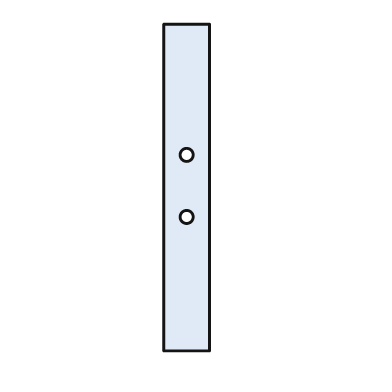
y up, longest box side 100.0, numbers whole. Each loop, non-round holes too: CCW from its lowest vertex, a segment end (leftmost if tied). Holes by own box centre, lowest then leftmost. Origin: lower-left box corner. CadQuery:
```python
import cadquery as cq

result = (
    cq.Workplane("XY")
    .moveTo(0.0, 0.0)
    .lineTo(14.0, 0.0)
    .lineTo(14.0, 100.0)
    .lineTo(0.0, 100.0)
    .close()
    .moveTo(7.0, 41.0)
    .circle(2.0)
    .moveTo(7.0, 60.0)
    .circle(2.0)
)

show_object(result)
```